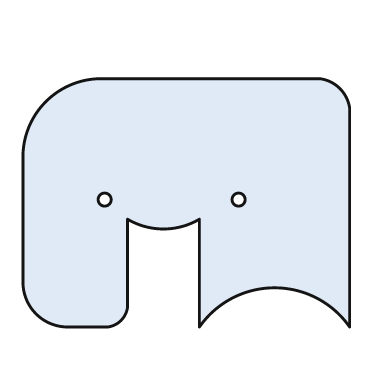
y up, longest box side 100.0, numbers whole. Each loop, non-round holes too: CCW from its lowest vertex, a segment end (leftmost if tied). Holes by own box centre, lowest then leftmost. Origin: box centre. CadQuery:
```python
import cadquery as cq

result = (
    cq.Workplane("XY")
    .moveTo(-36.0, -38.0)
    .lineTo(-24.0, -38.0)
    .threePointArc((-20.0, -36.0), (-18.0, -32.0))
    .lineTo(-18.0, -5.0)
    .threePointArc((-7.0, -8.0), (4.0, -5.0))
    .lineTo(4.0, -38.0)
    .threePointArc((27.0, -26.0), (50.0, -38.0))
    .lineTo(50.0, 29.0)
    .threePointArc((47.0, 35.0), (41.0, 38.0))
    .lineTo(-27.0, 38.0)
    .threePointArc((-43.0, 31.0), (-50.0, 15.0))
    .lineTo(-50.0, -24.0)
    .threePointArc((-46.0, -34.0), (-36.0, -38.0))
    .close()
    .moveTo(-25.0, 1.0)
    .circle(2.0)
    .moveTo(16.0, 1.0)
    .circle(2.0)
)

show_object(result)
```